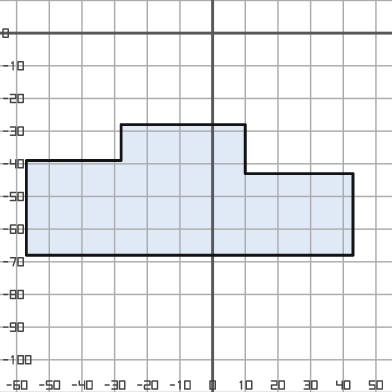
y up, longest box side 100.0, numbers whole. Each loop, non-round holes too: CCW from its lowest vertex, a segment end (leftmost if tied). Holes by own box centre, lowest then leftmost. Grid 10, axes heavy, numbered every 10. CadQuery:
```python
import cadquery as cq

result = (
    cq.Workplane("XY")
    .moveTo(-57.0, -68.0)
    .lineTo(43.0, -68.0)
    .lineTo(43.0, -43.0)
    .lineTo(10.0, -43.0)
    .lineTo(10.0, -28.0)
    .lineTo(-28.0, -28.0)
    .lineTo(-28.0, -39.0)
    .lineTo(-57.0, -39.0)
    .close()
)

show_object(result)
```